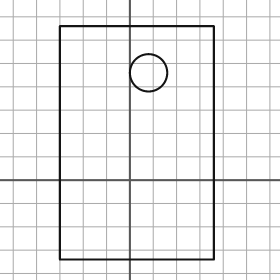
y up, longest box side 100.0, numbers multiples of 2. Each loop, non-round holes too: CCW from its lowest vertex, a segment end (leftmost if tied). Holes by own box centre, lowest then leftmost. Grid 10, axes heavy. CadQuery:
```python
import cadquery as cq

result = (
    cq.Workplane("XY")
    .moveTo(-30.0, -34.0)
    .lineTo(36.0, -34.0)
    .lineTo(36.0, 66.0)
    .lineTo(-30.0, 66.0)
    .close()
    .moveTo(8.0, 46.0)
    .circle(8.0)
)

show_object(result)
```